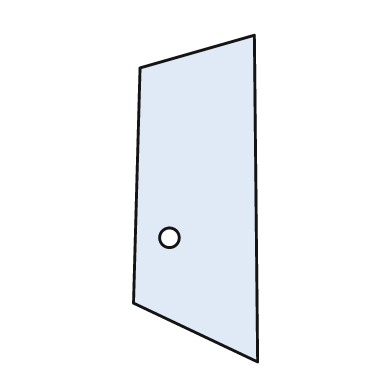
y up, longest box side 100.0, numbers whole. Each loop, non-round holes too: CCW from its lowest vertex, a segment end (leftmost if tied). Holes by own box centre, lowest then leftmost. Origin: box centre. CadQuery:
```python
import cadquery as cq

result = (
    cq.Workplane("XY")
    .moveTo(19.0, -50.0)
    .lineTo(18.0, 50.0)
    .lineTo(-17.0, 40.0)
    .lineTo(-19.0, -32.0)
    .close()
    .moveTo(-8.0, -12.0)
    .circle(3.0)
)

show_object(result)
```